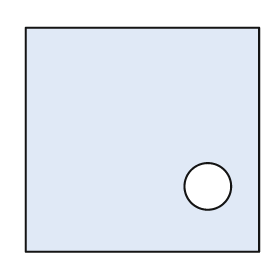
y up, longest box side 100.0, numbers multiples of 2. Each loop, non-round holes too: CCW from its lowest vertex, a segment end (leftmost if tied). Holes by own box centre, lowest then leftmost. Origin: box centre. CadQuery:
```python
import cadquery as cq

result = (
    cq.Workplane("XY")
    .moveTo(-50.0, -48.0)
    .lineTo(50.0, -48.0)
    .lineTo(50.0, 48.0)
    .lineTo(-50.0, 48.0)
    .close()
    .moveTo(28.0, -20.0)
    .circle(10.0)
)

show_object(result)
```